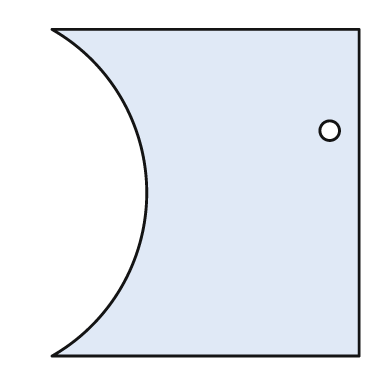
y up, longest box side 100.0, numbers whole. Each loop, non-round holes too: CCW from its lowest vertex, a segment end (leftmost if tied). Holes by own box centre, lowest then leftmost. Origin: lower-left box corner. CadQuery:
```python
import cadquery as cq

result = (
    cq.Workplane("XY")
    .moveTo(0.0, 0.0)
    .lineTo(94.0, 0.0)
    .lineTo(94.0, 100.0)
    .lineTo(0.0, 100.0)
    .threePointArc((29.0, 50.0), (0.0, 0.0))
    .close()
    .moveTo(85.0, 69.0)
    .circle(3.0)
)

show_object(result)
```